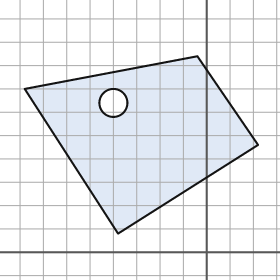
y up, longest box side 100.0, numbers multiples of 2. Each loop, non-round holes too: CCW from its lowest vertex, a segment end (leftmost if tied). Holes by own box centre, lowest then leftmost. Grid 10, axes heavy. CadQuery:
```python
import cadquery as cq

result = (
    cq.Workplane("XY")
    .moveTo(-38.0, 8.0)
    .lineTo(22.0, 46.0)
    .lineTo(-4.0, 84.0)
    .lineTo(-78.0, 70.0)
    .close()
    .moveTo(-40.0, 64.0)
    .circle(6.0)
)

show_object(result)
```